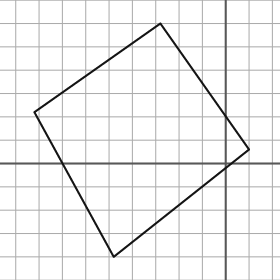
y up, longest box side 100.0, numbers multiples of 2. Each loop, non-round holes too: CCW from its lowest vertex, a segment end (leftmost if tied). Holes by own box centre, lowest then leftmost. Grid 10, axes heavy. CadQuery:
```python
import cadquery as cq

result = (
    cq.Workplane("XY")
    .moveTo(-48.0, -40.0)
    .lineTo(10.0, 6.0)
    .lineTo(-28.0, 60.0)
    .lineTo(-82.0, 22.0)
    .close()
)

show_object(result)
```